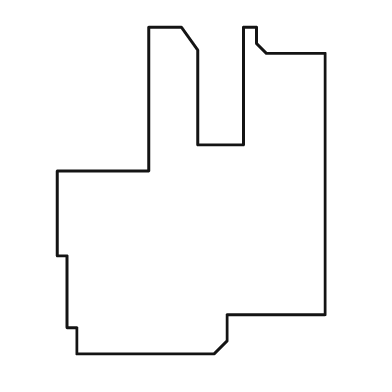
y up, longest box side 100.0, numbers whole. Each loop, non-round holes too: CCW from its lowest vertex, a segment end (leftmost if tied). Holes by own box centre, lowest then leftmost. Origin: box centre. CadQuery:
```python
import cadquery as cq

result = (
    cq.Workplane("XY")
    .moveTo(-35.0, -50.0)
    .lineTo(7.0, -50.0)
    .lineTo(11.0, -46.0)
    .lineTo(11.0, -38.0)
    .lineTo(41.0, -38.0)
    .lineTo(41.0, 42.0)
    .lineTo(23.0, 42.0)
    .lineTo(20.0, 45.0)
    .lineTo(20.0, 50.0)
    .lineTo(16.0, 50.0)
    .lineTo(16.0, 14.0)
    .lineTo(2.0, 14.0)
    .lineTo(2.0, 43.0)
    .lineTo(-3.0, 50.0)
    .lineTo(-13.0, 50.0)
    .lineTo(-13.0, 6.0)
    .lineTo(-41.0, 6.0)
    .lineTo(-41.0, -20.0)
    .lineTo(-38.0, -20.0)
    .lineTo(-38.0, -42.0)
    .lineTo(-35.0, -42.0)
    .close()
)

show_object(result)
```